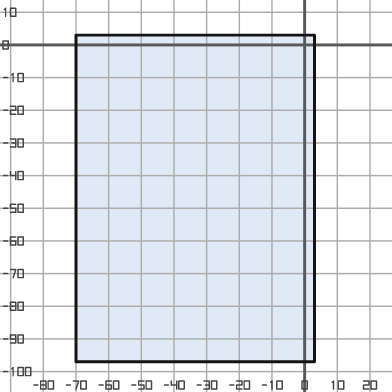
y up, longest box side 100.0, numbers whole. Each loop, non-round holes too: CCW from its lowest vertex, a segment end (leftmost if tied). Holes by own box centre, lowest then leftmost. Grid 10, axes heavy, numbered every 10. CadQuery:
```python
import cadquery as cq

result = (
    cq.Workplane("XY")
    .moveTo(-70.0, -97.0)
    .lineTo(3.0, -97.0)
    .lineTo(3.0, 3.0)
    .lineTo(-70.0, 3.0)
    .close()
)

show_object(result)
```